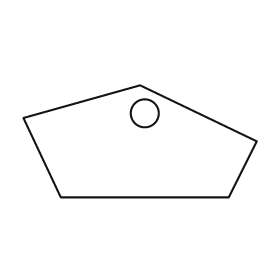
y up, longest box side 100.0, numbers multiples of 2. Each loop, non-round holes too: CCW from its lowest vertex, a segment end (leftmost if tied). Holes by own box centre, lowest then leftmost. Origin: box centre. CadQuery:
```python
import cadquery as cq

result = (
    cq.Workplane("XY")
    .moveTo(-34.0, -24.0)
    .lineTo(38.0, -24.0)
    .lineTo(50.0, 0.0)
    .lineTo(0.0, 24.0)
    .lineTo(-50.0, 10.0)
    .close()
    .moveTo(2.0, 12.0)
    .circle(6.0)
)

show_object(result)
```